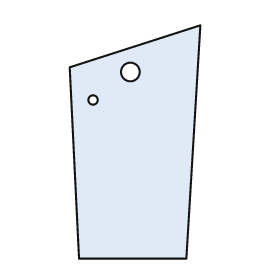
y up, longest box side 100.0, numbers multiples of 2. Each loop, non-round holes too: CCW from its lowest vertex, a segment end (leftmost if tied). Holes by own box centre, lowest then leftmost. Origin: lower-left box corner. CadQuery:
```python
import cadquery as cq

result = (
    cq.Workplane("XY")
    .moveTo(4.0, 0.0)
    .lineTo(50.0, 0.0)
    .lineTo(56.0, 100.0)
    .lineTo(0.0, 82.0)
    .close()
    .moveTo(10.0, 68.0)
    .circle(2.0)
    .moveTo(26.0, 80.0)
    .circle(4.0)
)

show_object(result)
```